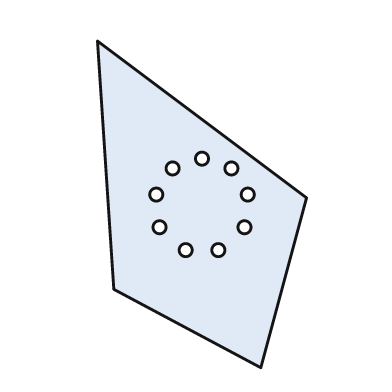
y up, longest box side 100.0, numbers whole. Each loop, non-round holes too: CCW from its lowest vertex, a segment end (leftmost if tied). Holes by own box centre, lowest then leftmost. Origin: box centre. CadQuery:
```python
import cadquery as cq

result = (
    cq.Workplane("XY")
    .moveTo(18.0, -50.0)
    .lineTo(32.0, 2.0)
    .lineTo(-32.0, 50.0)
    .lineTo(-27.0, -26.0)
    .close()
    .moveTo(-5.0, -14.0)
    .circle(2.0)
    .moveTo(5.0, -14.0)
    .circle(2.0)
    .moveTo(-13.0, -7.0)
    .circle(2.0)
    .moveTo(13.0, -7.0)
    .circle(2.0)
    .moveTo(-14.0, 3.0)
    .circle(2.0)
    .moveTo(14.0, 3.0)
    .circle(2.0)
    .moveTo(-9.0, 11.0)
    .circle(2.0)
    .moveTo(9.0, 11.0)
    .circle(2.0)
    .moveTo(0.0, 14.0)
    .circle(2.0)
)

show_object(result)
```